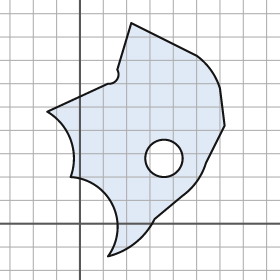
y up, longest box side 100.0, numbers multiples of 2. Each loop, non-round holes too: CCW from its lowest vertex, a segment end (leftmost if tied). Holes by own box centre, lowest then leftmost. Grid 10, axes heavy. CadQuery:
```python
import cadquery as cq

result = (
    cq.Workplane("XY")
    .moveTo(12.0, -14.0)
    .threePointArc((24.0, -8.0), (32.0, 2.0))
    .lineTo(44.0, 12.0)
    .threePointArc((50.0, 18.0), (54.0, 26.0))
    .lineTo(62.0, 42.0)
    .lineTo(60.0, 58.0)
    .threePointArc((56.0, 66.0), (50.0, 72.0))
    .lineTo(22.0, 86.0)
    .lineTo(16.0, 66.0)
    .threePointArc((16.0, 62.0), (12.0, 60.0))
    .lineTo(-14.0, 48.0)
    .threePointArc((-4.0, 36.0), (-4.0, 20.0))
    .threePointArc((14.0, 8.0), (12.0, -14.0))
    .close()
    .moveTo(36.0, 28.0)
    .circle(8.0)
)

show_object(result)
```